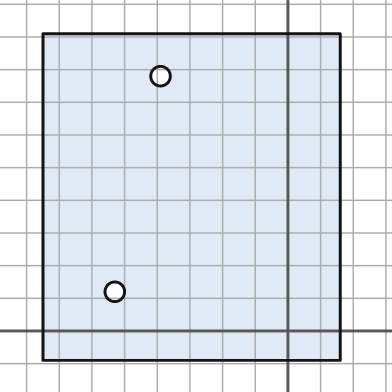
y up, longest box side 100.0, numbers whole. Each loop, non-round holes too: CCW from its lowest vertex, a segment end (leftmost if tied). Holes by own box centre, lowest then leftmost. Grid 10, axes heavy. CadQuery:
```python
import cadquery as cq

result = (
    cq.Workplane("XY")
    .moveTo(-75.0, -9.0)
    .lineTo(16.0, -9.0)
    .lineTo(16.0, 91.0)
    .lineTo(-75.0, 91.0)
    .close()
    .moveTo(-53.0, 12.0)
    .circle(3.0)
    .moveTo(-39.0, 78.0)
    .circle(3.0)
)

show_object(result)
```